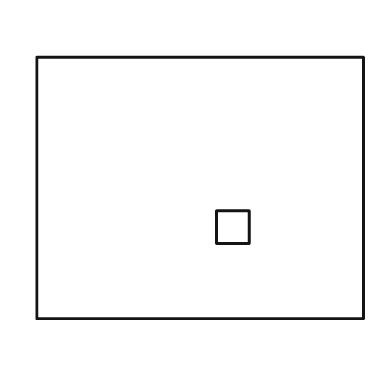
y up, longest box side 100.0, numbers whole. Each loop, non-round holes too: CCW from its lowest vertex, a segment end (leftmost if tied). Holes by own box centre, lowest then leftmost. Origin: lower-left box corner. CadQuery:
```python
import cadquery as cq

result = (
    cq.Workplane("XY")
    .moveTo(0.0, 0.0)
    .lineTo(100.0, 0.0)
    .lineTo(100.0, 80.0)
    .lineTo(0.0, 80.0)
    .close()
    .moveTo(55.0, 23.0)
    .lineTo(65.0, 23.0)
    .lineTo(65.0, 33.0)
    .lineTo(55.0, 33.0)
    .close()
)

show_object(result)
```